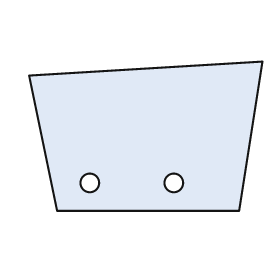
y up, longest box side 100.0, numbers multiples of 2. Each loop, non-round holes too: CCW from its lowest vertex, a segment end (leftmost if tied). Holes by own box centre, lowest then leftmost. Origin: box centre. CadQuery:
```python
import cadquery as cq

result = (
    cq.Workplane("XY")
    .moveTo(-38.0, -32.0)
    .lineTo(40.0, -32.0)
    .lineTo(50.0, 32.0)
    .lineTo(-50.0, 26.0)
    .close()
    .moveTo(-24.0, -20.0)
    .circle(4.0)
    .moveTo(12.0, -20.0)
    .circle(4.0)
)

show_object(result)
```